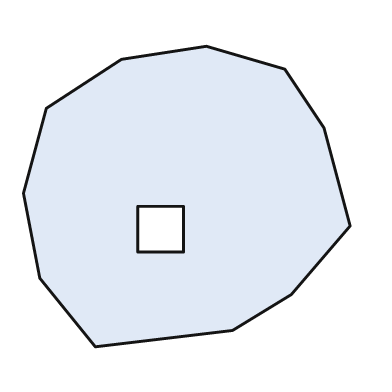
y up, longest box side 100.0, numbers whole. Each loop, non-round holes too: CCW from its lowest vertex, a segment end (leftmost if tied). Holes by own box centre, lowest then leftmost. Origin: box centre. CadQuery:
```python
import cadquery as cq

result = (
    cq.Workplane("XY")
    .moveTo(-28.0, -46.0)
    .lineTo(14.0, -41.0)
    .lineTo(32.0, -30.0)
    .lineTo(50.0, -9.0)
    .lineTo(42.0, 21.0)
    .lineTo(30.0, 39.0)
    .lineTo(6.0, 46.0)
    .lineTo(-20.0, 42.0)
    .lineTo(-43.0, 27.0)
    .lineTo(-50.0, 1.0)
    .lineTo(-45.0, -25.0)
    .close()
    .moveTo(-15.0, -17.0)
    .lineTo(-1.0, -17.0)
    .lineTo(-1.0, -3.0)
    .lineTo(-15.0, -3.0)
    .close()
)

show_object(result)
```